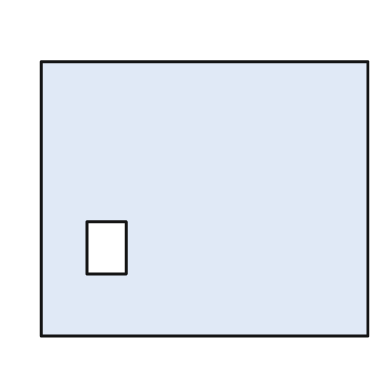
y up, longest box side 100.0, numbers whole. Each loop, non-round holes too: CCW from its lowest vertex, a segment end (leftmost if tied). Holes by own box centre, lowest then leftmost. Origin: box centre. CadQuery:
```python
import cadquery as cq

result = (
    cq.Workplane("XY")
    .moveTo(-50.0, -42.0)
    .lineTo(50.0, -42.0)
    .lineTo(50.0, 42.0)
    .lineTo(-50.0, 42.0)
    .close()
    .moveTo(-36.0, -23.0)
    .lineTo(-24.0, -23.0)
    .lineTo(-24.0, -7.0)
    .lineTo(-36.0, -7.0)
    .close()
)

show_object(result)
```